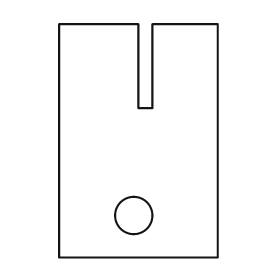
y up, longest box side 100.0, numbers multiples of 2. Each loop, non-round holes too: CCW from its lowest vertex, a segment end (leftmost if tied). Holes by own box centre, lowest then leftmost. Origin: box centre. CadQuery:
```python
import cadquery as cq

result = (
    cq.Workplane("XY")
    .moveTo(-34.0, -50.0)
    .lineTo(34.0, -50.0)
    .lineTo(34.0, 50.0)
    .lineTo(6.0, 50.0)
    .lineTo(6.0, 14.0)
    .lineTo(0.0, 14.0)
    .lineTo(0.0, 50.0)
    .lineTo(-34.0, 50.0)
    .close()
    .moveTo(-2.0, -32.0)
    .circle(8.0)
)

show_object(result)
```